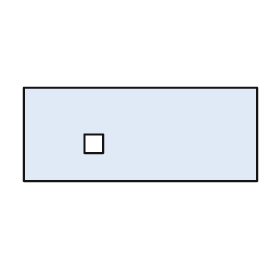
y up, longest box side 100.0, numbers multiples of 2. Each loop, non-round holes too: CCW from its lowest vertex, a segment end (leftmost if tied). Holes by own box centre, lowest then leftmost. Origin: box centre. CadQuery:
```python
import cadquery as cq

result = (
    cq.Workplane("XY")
    .moveTo(-50.0, -20.0)
    .lineTo(50.0, -20.0)
    .lineTo(50.0, 20.0)
    .lineTo(-50.0, 20.0)
    .close()
    .moveTo(-24.0, -8.0)
    .lineTo(-16.0, -8.0)
    .lineTo(-16.0, 0.0)
    .lineTo(-24.0, 0.0)
    .close()
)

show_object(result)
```